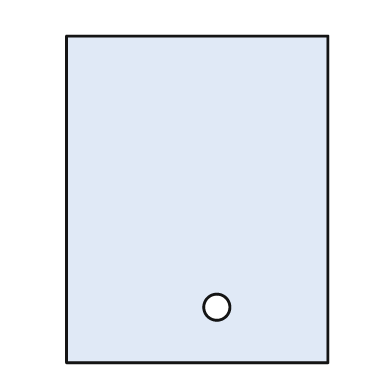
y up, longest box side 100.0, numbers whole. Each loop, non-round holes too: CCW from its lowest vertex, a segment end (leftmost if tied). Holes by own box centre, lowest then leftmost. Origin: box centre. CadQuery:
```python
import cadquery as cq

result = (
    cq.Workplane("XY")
    .moveTo(-40.0, -50.0)
    .lineTo(40.0, -50.0)
    .lineTo(40.0, 50.0)
    .lineTo(-40.0, 50.0)
    .close()
    .moveTo(6.0, -33.0)
    .circle(4.0)
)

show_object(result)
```